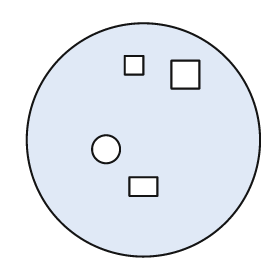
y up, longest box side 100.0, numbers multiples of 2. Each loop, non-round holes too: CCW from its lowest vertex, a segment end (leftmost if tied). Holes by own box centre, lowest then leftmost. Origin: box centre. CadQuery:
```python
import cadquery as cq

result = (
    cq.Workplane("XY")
    .moveTo(0.0, 0.0)
    .circle(50.0)
    .moveTo(-6.0, -24.0)
    .lineTo(6.0, -24.0)
    .lineTo(6.0, -16.0)
    .lineTo(-6.0, -16.0)
    .close()
    .moveTo(-16.0, -4.0)
    .circle(6.0)
    .moveTo(12.0, 22.0)
    .lineTo(24.0, 22.0)
    .lineTo(24.0, 34.0)
    .lineTo(12.0, 34.0)
    .close()
    .moveTo(-8.0, 28.0)
    .lineTo(0.0, 28.0)
    .lineTo(0.0, 36.0)
    .lineTo(-8.0, 36.0)
    .close()
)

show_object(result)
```